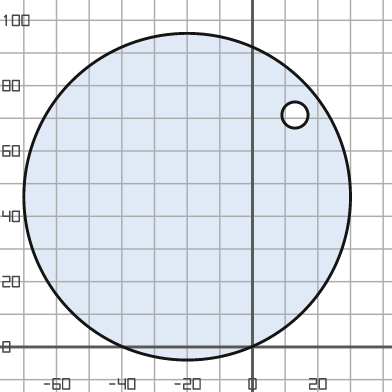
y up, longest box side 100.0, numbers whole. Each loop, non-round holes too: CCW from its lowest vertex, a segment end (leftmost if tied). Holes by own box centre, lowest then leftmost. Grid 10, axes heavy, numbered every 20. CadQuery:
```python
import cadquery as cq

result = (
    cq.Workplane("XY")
    .moveTo(-20.0, 46.0)
    .circle(50.0)
    .moveTo(13.0, 71.0)
    .circle(4.0)
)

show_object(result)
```